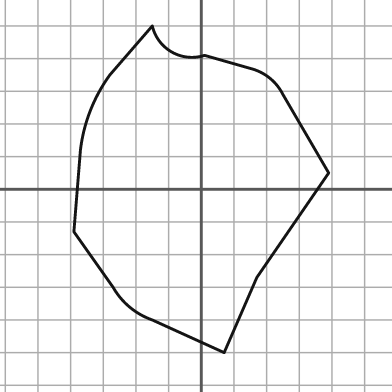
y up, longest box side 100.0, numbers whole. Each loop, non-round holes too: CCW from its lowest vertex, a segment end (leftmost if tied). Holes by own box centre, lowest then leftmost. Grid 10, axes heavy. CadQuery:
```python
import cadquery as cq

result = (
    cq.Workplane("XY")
    .moveTo(7.0, -50.0)
    .lineTo(17.0, -27.0)
    .lineTo(39.0, 5.0)
    .lineTo(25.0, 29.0)
    .threePointArc((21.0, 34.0), (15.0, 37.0))
    .lineTo(1.0, 41.0)
    .threePointArc((-9.0, 42.0), (-15.0, 50.0))
    .lineTo(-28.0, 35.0)
    .threePointArc((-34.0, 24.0), (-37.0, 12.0))
    .lineTo(-39.0, -13.0)
    .lineTo(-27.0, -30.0)
    .threePointArc((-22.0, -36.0), (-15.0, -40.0))
    .close()
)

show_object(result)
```